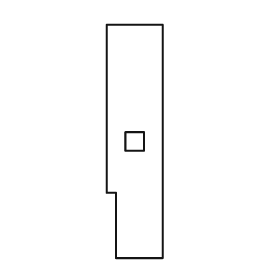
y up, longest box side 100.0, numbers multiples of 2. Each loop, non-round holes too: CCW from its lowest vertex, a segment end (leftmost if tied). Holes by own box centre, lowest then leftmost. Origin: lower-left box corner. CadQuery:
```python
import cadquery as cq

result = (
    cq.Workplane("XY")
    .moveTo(4.0, 0.0)
    .lineTo(24.0, 0.0)
    .lineTo(24.0, 100.0)
    .lineTo(0.0, 100.0)
    .lineTo(0.0, 28.0)
    .lineTo(4.0, 28.0)
    .close()
    .moveTo(8.0, 46.0)
    .lineTo(16.0, 46.0)
    .lineTo(16.0, 54.0)
    .lineTo(8.0, 54.0)
    .close()
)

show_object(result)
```